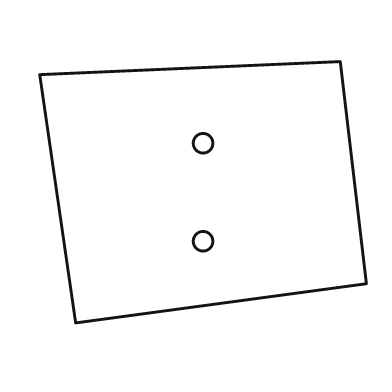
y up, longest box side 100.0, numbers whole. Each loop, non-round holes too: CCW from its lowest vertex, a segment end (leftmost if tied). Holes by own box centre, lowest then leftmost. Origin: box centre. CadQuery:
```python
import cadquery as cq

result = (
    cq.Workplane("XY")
    .moveTo(-39.0, -40.0)
    .lineTo(50.0, -28.0)
    .lineTo(42.0, 40.0)
    .lineTo(-50.0, 36.0)
    .close()
    .moveTo(0.0, -15.0)
    .circle(3.0)
    .moveTo(0.0, 15.0)
    .circle(3.0)
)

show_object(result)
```